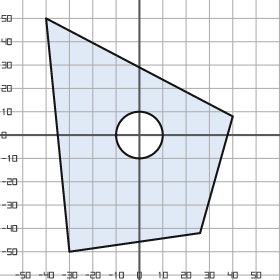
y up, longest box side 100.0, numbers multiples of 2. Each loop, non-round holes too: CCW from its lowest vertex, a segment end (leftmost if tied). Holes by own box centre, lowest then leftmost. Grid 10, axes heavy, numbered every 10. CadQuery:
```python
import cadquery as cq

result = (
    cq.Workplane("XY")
    .moveTo(-30.0, -50.0)
    .lineTo(26.0, -42.0)
    .lineTo(40.0, 8.0)
    .lineTo(-40.0, 50.0)
    .close()
    .moveTo(0.0, 0.0)
    .circle(10.0)
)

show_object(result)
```